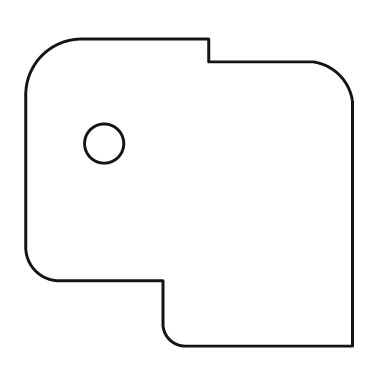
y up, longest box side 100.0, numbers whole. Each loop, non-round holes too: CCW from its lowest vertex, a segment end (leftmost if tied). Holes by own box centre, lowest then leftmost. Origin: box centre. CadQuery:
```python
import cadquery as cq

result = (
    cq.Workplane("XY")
    .moveTo(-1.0, -47.0)
    .lineTo(50.0, -47.0)
    .lineTo(50.0, 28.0)
    .threePointArc((46.0, 36.0), (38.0, 40.0))
    .lineTo(6.0, 40.0)
    .lineTo(6.0, 47.0)
    .lineTo(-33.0, 47.0)
    .threePointArc((-45.0, 42.0), (-50.0, 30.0))
    .lineTo(-50.0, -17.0)
    .threePointArc((-47.0, -24.0), (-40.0, -27.0))
    .lineTo(-8.0, -27.0)
    .lineTo(-8.0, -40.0)
    .threePointArc((-6.0, -45.0), (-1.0, -47.0))
    .close()
    .moveTo(-26.0, 15.0)
    .circle(6.0)
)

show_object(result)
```